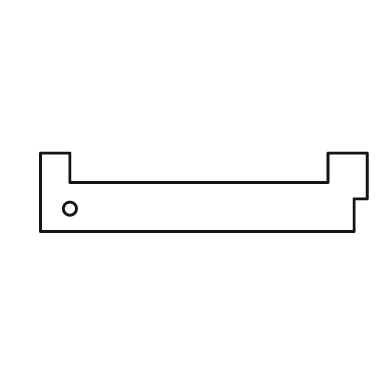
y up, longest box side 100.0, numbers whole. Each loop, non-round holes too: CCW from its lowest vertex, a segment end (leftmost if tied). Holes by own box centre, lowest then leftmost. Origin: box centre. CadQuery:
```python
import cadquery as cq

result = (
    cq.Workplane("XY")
    .moveTo(-50.0, -12.0)
    .lineTo(46.0, -12.0)
    .lineTo(46.0, -2.0)
    .lineTo(50.0, -2.0)
    .lineTo(50.0, 12.0)
    .lineTo(38.0, 12.0)
    .lineTo(38.0, 3.0)
    .lineTo(-41.0, 3.0)
    .lineTo(-41.0, 12.0)
    .lineTo(-50.0, 12.0)
    .close()
    .moveTo(-41.0, -5.0)
    .circle(2.0)
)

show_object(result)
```